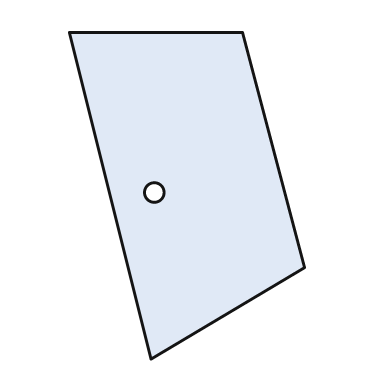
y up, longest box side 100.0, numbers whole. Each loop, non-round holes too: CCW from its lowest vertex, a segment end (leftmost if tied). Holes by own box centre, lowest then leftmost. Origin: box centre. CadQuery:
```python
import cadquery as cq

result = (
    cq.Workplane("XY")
    .moveTo(-11.0, -50.0)
    .lineTo(36.0, -22.0)
    .lineTo(17.0, 50.0)
    .lineTo(-36.0, 50.0)
    .close()
    .moveTo(-10.0, 1.0)
    .circle(3.0)
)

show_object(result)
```